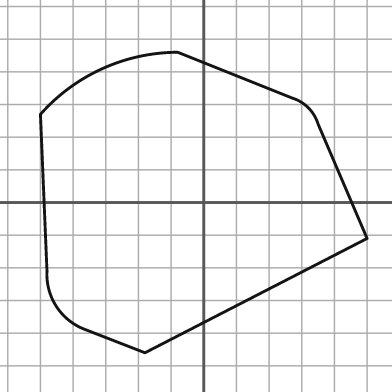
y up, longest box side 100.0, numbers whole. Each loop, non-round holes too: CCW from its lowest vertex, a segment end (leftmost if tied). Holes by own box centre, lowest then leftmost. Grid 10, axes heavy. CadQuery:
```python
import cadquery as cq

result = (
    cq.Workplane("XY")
    .moveTo(-18.0, -46.0)
    .lineTo(50.0, -11.0)
    .lineTo(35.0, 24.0)
    .threePointArc((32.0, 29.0), (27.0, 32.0))
    .lineTo(-8.0, 46.0)
    .threePointArc((-31.0, 41.0), (-50.0, 27.0))
    .lineTo(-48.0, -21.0)
    .threePointArc((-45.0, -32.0), (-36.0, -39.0))
    .close()
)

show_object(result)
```